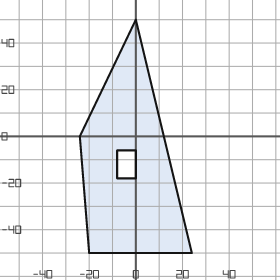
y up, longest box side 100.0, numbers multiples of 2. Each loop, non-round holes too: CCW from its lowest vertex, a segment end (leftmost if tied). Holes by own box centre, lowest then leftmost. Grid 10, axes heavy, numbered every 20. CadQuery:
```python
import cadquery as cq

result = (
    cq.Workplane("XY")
    .moveTo(-20.0, -50.0)
    .lineTo(24.0, -50.0)
    .lineTo(0.0, 50.0)
    .lineTo(-24.0, 0.0)
    .close()
    .moveTo(-8.0, -18.0)
    .lineTo(0.0, -18.0)
    .lineTo(0.0, -6.0)
    .lineTo(-8.0, -6.0)
    .close()
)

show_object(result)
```